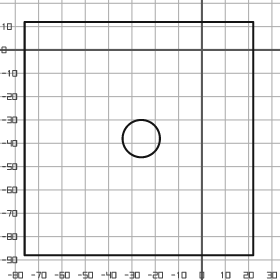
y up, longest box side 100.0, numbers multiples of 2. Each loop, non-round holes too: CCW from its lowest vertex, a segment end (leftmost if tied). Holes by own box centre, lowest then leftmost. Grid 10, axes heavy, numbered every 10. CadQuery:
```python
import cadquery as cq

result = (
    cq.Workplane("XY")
    .moveTo(-76.0, -88.0)
    .lineTo(22.0, -88.0)
    .lineTo(22.0, 12.0)
    .lineTo(-76.0, 12.0)
    .close()
    .moveTo(-26.0, -38.0)
    .circle(8.0)
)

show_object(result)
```